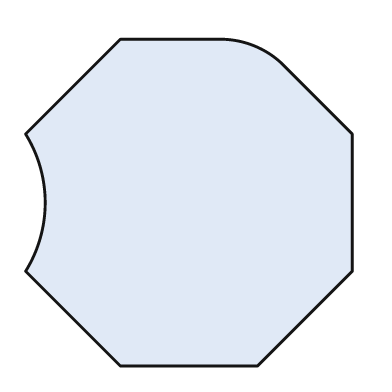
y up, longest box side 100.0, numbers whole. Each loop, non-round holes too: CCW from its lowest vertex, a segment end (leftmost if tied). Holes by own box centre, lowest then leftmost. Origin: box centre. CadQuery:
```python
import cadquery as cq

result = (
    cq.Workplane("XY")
    .moveTo(-21.0, -50.0)
    .lineTo(21.0, -50.0)
    .lineTo(50.0, -21.0)
    .lineTo(50.0, 21.0)
    .lineTo(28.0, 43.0)
    .threePointArc((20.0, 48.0), (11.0, 50.0))
    .lineTo(-21.0, 50.0)
    .lineTo(-50.0, 21.0)
    .threePointArc((-44.0, 0.0), (-50.0, -21.0))
    .close()
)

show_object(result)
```